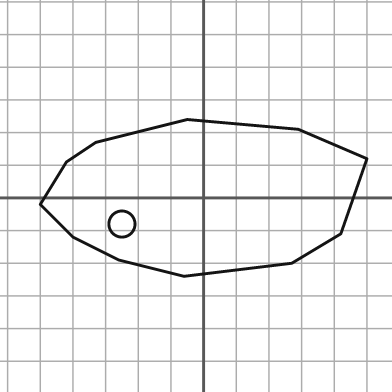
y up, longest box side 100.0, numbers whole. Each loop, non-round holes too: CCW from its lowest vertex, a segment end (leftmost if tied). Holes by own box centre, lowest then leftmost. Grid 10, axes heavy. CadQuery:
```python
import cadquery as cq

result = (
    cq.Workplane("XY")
    .moveTo(-6.0, -24.0)
    .lineTo(27.0, -20.0)
    .lineTo(42.0, -11.0)
    .lineTo(50.0, 12.0)
    .lineTo(29.0, 21.0)
    .lineTo(-5.0, 24.0)
    .lineTo(-33.0, 17.0)
    .lineTo(-42.0, 11.0)
    .lineTo(-50.0, -2.0)
    .lineTo(-40.0, -12.0)
    .lineTo(-26.0, -19.0)
    .close()
    .moveTo(-25.0, -8.0)
    .circle(4.0)
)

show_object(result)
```